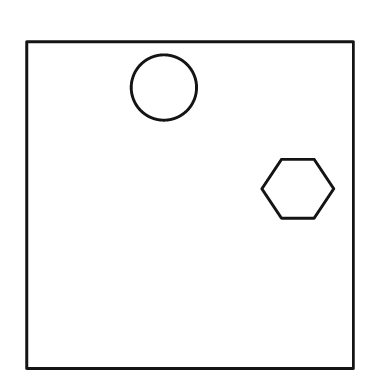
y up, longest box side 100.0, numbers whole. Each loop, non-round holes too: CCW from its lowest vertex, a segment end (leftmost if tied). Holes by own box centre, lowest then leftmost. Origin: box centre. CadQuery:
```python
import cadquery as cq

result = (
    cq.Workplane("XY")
    .moveTo(-50.0, -50.0)
    .lineTo(50.0, -50.0)
    .lineTo(50.0, 50.0)
    .lineTo(-50.0, 50.0)
    .close()
    .moveTo(28.0, -4.0)
    .lineTo(38.0, -4.0)
    .lineTo(44.0, 5.0)
    .lineTo(38.0, 14.0)
    .lineTo(28.0, 14.0)
    .lineTo(22.0, 5.0)
    .close()
    .moveTo(-8.0, 36.0)
    .circle(10.0)
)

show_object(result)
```